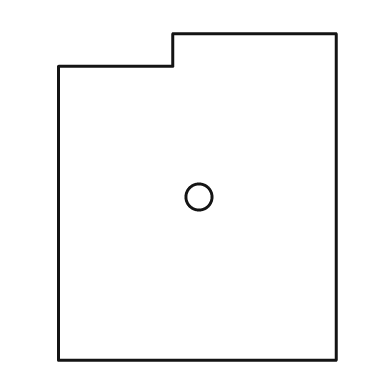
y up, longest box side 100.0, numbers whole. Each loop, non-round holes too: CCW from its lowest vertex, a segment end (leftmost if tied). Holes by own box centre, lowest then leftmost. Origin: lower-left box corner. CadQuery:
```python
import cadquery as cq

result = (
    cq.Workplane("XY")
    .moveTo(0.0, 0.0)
    .lineTo(85.0, 0.0)
    .lineTo(85.0, 100.0)
    .lineTo(35.0, 100.0)
    .lineTo(35.0, 90.0)
    .lineTo(0.0, 90.0)
    .close()
    .moveTo(43.0, 50.0)
    .circle(4.0)
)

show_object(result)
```